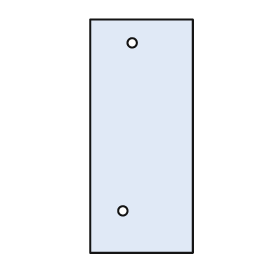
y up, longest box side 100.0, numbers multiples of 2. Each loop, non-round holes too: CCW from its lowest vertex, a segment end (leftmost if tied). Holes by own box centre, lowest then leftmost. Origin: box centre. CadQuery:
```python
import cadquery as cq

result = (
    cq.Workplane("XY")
    .moveTo(-22.0, -50.0)
    .lineTo(22.0, -50.0)
    .lineTo(22.0, 50.0)
    .lineTo(-22.0, 50.0)
    .close()
    .moveTo(-8.0, -32.0)
    .circle(2.0)
    .moveTo(-4.0, 40.0)
    .circle(2.0)
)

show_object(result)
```